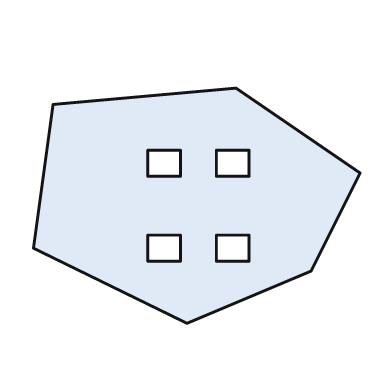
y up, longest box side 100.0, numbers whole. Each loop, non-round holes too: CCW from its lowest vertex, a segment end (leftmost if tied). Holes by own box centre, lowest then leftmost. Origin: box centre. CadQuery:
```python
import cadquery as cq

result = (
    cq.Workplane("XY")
    .moveTo(-3.0, -36.0)
    .lineTo(35.0, -20.0)
    .lineTo(50.0, 10.0)
    .lineTo(12.0, 36.0)
    .lineTo(-44.0, 31.0)
    .lineTo(-50.0, -13.0)
    .close()
    .moveTo(-15.0, -17.0)
    .lineTo(-5.0, -17.0)
    .lineTo(-5.0, -9.0)
    .lineTo(-15.0, -9.0)
    .close()
    .moveTo(6.0, -17.0)
    .lineTo(16.0, -17.0)
    .lineTo(16.0, -9.0)
    .lineTo(6.0, -9.0)
    .close()
    .moveTo(-15.0, 9.0)
    .lineTo(-5.0, 9.0)
    .lineTo(-5.0, 17.0)
    .lineTo(-15.0, 17.0)
    .close()
    .moveTo(6.0, 9.0)
    .lineTo(16.0, 9.0)
    .lineTo(16.0, 17.0)
    .lineTo(6.0, 17.0)
    .close()
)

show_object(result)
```